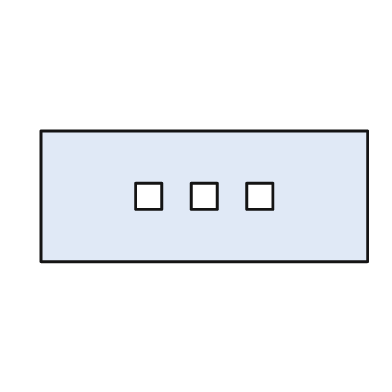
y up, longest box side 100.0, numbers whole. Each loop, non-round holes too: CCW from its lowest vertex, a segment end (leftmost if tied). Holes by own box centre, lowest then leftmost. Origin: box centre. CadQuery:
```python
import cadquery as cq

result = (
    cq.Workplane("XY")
    .moveTo(-50.0, -20.0)
    .lineTo(50.0, -20.0)
    .lineTo(50.0, 20.0)
    .lineTo(-50.0, 20.0)
    .close()
    .moveTo(-21.0, -4.0)
    .lineTo(-13.0, -4.0)
    .lineTo(-13.0, 4.0)
    .lineTo(-21.0, 4.0)
    .close()
    .moveTo(-4.0, -4.0)
    .lineTo(4.0, -4.0)
    .lineTo(4.0, 4.0)
    .lineTo(-4.0, 4.0)
    .close()
    .moveTo(13.0, -4.0)
    .lineTo(21.0, -4.0)
    .lineTo(21.0, 4.0)
    .lineTo(13.0, 4.0)
    .close()
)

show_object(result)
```